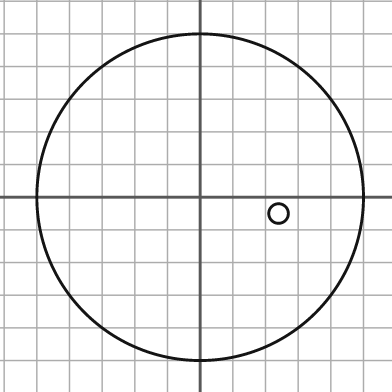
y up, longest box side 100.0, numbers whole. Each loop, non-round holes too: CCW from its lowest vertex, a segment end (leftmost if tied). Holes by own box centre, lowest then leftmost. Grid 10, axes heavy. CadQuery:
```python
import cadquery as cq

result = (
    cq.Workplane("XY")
    .moveTo(0.0, 0.0)
    .circle(50.0)
    .moveTo(24.0, -5.0)
    .circle(3.0)
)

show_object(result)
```